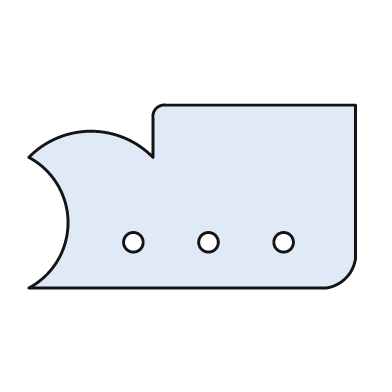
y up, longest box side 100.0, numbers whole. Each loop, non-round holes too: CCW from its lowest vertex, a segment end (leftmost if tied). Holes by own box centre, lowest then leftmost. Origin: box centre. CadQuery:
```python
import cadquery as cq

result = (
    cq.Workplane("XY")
    .moveTo(-50.0, -28.0)
    .lineTo(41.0, -28.0)
    .threePointArc((47.0, -25.0), (50.0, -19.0))
    .lineTo(50.0, 28.0)
    .lineTo(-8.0, 28.0)
    .threePointArc((-11.0, 27.0), (-12.0, 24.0))
    .lineTo(-12.0, 12.0)
    .threePointArc((-31.0, 20.0), (-50.0, 12.0))
    .threePointArc((-38.0, -8.0), (-50.0, -28.0))
    .close()
    .moveTo(-18.0, -14.0)
    .circle(3.0)
    .moveTo(5.0, -14.0)
    .circle(3.0)
    .moveTo(28.0, -14.0)
    .circle(3.0)
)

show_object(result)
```